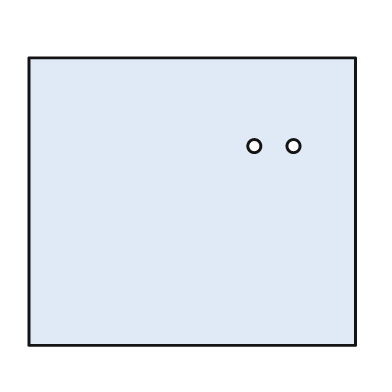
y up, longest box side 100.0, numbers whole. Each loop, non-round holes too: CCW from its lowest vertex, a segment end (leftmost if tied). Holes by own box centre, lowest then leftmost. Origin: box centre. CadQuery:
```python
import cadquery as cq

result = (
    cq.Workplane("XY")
    .moveTo(-50.0, -44.0)
    .lineTo(50.0, -44.0)
    .lineTo(50.0, 44.0)
    .lineTo(-50.0, 44.0)
    .close()
    .moveTo(19.0, 17.0)
    .circle(2.0)
    .moveTo(31.0, 17.0)
    .circle(2.0)
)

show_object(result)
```